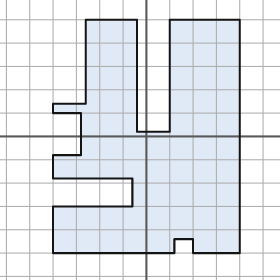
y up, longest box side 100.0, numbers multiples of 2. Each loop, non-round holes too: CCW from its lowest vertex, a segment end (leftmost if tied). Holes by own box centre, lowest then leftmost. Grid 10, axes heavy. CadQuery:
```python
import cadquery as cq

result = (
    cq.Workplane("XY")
    .moveTo(-40.0, -50.0)
    .lineTo(12.0, -50.0)
    .lineTo(12.0, -44.0)
    .lineTo(20.0, -44.0)
    .lineTo(20.0, -50.0)
    .lineTo(40.0, -50.0)
    .lineTo(40.0, 50.0)
    .lineTo(10.0, 50.0)
    .lineTo(10.0, 2.0)
    .lineTo(-4.0, 2.0)
    .lineTo(-4.0, 50.0)
    .lineTo(-26.0, 50.0)
    .lineTo(-26.0, 14.0)
    .lineTo(-40.0, 14.0)
    .lineTo(-40.0, 10.0)
    .lineTo(-28.0, 10.0)
    .lineTo(-28.0, -8.0)
    .lineTo(-40.0, -8.0)
    .lineTo(-40.0, -18.0)
    .lineTo(-6.0, -18.0)
    .lineTo(-6.0, -30.0)
    .lineTo(-40.0, -30.0)
    .close()
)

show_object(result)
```